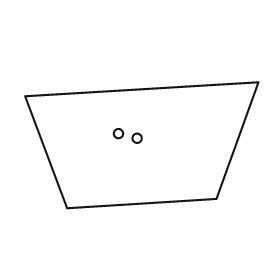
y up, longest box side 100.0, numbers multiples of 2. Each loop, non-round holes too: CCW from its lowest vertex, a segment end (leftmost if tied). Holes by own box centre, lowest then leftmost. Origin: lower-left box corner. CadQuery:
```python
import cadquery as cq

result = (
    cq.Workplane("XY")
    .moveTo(18.0, 0.0)
    .lineTo(82.0, 4.0)
    .lineTo(100.0, 54.0)
    .lineTo(0.0, 48.0)
    .close()
    .moveTo(48.0, 30.0)
    .circle(2.0)
    .moveTo(40.0, 32.0)
    .circle(2.0)
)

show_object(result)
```